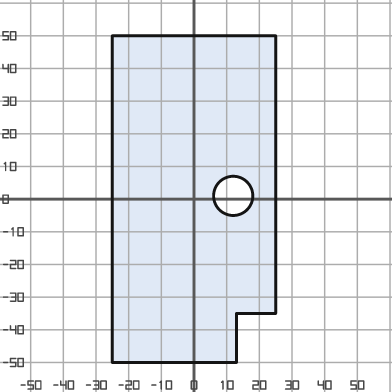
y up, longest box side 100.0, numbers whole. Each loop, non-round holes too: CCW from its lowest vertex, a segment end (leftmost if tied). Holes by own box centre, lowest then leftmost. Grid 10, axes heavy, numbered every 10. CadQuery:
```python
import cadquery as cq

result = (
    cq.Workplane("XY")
    .moveTo(-25.0, -50.0)
    .lineTo(13.0, -50.0)
    .lineTo(13.0, -35.0)
    .lineTo(25.0, -35.0)
    .lineTo(25.0, 50.0)
    .lineTo(-25.0, 50.0)
    .close()
    .moveTo(12.0, 1.0)
    .circle(6.0)
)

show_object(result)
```